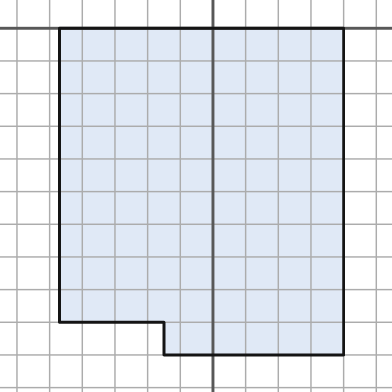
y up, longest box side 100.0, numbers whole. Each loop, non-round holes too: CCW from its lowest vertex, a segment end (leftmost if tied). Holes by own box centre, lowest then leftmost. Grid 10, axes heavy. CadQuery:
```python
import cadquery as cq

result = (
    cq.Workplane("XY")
    .moveTo(-15.0, -100.0)
    .lineTo(40.0, -100.0)
    .lineTo(40.0, 0.0)
    .lineTo(-47.0, 0.0)
    .lineTo(-47.0, -90.0)
    .lineTo(-15.0, -90.0)
    .close()
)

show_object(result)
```